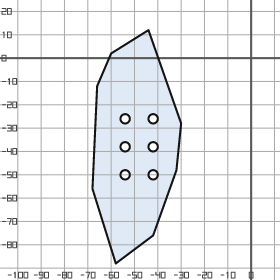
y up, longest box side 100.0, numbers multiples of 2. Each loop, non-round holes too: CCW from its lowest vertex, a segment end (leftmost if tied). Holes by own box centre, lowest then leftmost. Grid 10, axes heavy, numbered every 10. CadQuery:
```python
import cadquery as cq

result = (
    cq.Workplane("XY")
    .moveTo(-58.0, -88.0)
    .lineTo(-42.0, -76.0)
    .lineTo(-32.0, -48.0)
    .lineTo(-30.0, -28.0)
    .lineTo(-44.0, 12.0)
    .lineTo(-60.0, 2.0)
    .lineTo(-66.0, -12.0)
    .lineTo(-68.0, -56.0)
    .close()
    .moveTo(-54.0, -50.0)
    .circle(2.0)
    .moveTo(-42.0, -50.0)
    .circle(2.0)
    .moveTo(-54.0, -38.0)
    .circle(2.0)
    .moveTo(-42.0, -38.0)
    .circle(2.0)
    .moveTo(-54.0, -26.0)
    .circle(2.0)
    .moveTo(-42.0, -26.0)
    .circle(2.0)
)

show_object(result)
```